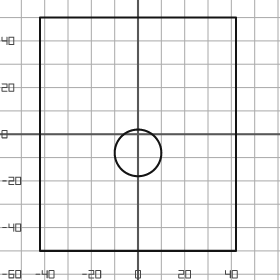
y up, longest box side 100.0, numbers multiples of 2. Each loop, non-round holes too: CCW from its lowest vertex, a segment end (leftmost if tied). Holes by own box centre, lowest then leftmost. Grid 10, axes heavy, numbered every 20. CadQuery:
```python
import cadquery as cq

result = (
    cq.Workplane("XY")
    .moveTo(-42.0, -50.0)
    .lineTo(42.0, -50.0)
    .lineTo(42.0, 50.0)
    .lineTo(-42.0, 50.0)
    .close()
    .moveTo(0.0, -8.0)
    .circle(10.0)
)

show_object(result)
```